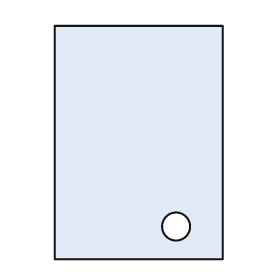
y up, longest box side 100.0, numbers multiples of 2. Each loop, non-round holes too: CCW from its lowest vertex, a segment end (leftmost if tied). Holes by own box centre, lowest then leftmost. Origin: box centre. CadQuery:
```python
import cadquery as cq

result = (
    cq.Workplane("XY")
    .moveTo(-36.0, -50.0)
    .lineTo(36.0, -50.0)
    .lineTo(36.0, 50.0)
    .lineTo(-36.0, 50.0)
    .close()
    .moveTo(16.0, -36.0)
    .circle(6.0)
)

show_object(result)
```